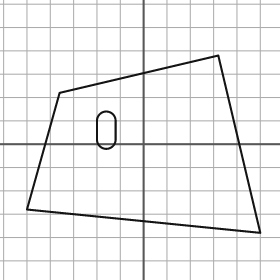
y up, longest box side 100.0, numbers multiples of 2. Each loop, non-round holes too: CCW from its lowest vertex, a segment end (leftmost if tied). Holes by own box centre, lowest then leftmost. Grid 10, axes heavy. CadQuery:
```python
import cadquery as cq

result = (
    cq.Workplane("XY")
    .moveTo(50.0, -38.0)
    .lineTo(32.0, 38.0)
    .lineTo(-36.0, 22.0)
    .lineTo(-50.0, -28.0)
    .close()
    .moveTo(-20.0, 2.0)
    .threePointArc((-16.0, -2.0), (-12.0, 2.0))
    .lineTo(-12.0, 10.0)
    .threePointArc((-16.0, 14.0), (-20.0, 10.0))
    .close()
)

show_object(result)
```